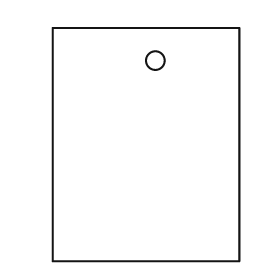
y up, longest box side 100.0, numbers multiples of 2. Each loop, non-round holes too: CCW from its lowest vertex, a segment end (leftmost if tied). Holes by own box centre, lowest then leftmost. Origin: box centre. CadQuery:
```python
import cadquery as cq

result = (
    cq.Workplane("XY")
    .moveTo(-40.0, -50.0)
    .lineTo(40.0, -50.0)
    .lineTo(40.0, 50.0)
    .lineTo(-40.0, 50.0)
    .close()
    .moveTo(4.0, 36.0)
    .circle(4.0)
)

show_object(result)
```